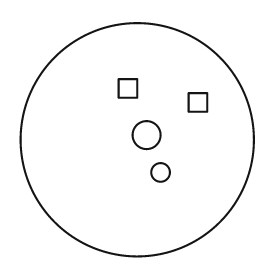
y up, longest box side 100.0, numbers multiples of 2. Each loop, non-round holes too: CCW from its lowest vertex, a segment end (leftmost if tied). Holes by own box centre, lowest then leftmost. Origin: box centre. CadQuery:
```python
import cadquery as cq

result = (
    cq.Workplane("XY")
    .moveTo(0.0, 0.0)
    .circle(50.0)
    .moveTo(10.0, -14.0)
    .circle(4.0)
    .moveTo(4.0, 2.0)
    .circle(6.0)
    .moveTo(22.0, 12.0)
    .lineTo(30.0, 12.0)
    .lineTo(30.0, 20.0)
    .lineTo(22.0, 20.0)
    .close()
    .moveTo(-8.0, 18.0)
    .lineTo(0.0, 18.0)
    .lineTo(0.0, 26.0)
    .lineTo(-8.0, 26.0)
    .close()
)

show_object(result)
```